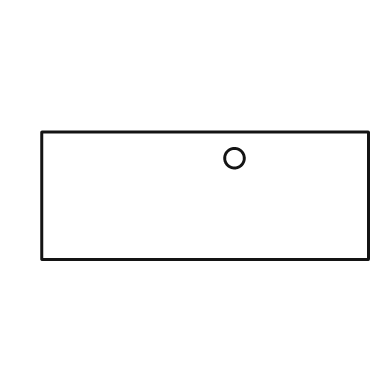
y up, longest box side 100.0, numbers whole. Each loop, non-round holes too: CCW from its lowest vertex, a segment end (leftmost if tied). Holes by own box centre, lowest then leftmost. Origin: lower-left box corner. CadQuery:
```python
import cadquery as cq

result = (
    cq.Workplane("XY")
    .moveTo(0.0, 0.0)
    .lineTo(100.0, 0.0)
    .lineTo(100.0, 39.0)
    .lineTo(0.0, 39.0)
    .close()
    .moveTo(59.0, 31.0)
    .circle(3.0)
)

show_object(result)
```